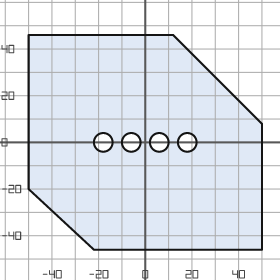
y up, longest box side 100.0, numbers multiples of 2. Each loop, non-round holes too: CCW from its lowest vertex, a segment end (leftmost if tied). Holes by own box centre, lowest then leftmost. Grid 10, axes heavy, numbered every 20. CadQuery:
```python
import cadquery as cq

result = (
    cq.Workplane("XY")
    .moveTo(-22.0, -46.0)
    .lineTo(50.0, -46.0)
    .lineTo(50.0, 8.0)
    .lineTo(12.0, 46.0)
    .lineTo(-50.0, 46.0)
    .lineTo(-50.0, -20.0)
    .close()
    .moveTo(-18.0, 0.0)
    .circle(4.0)
    .moveTo(-6.0, 0.0)
    .circle(4.0)
    .moveTo(6.0, 0.0)
    .circle(4.0)
    .moveTo(18.0, 0.0)
    .circle(4.0)
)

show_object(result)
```